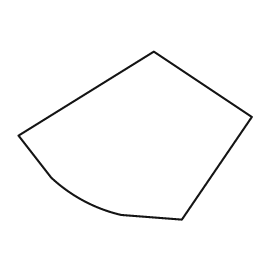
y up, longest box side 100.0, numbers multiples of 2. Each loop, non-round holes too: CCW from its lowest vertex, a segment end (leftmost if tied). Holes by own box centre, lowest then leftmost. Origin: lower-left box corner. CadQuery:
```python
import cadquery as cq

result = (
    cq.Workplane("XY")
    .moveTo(70.0, 0.0)
    .lineTo(100.0, 44.0)
    .lineTo(58.0, 72.0)
    .lineTo(0.0, 36.0)
    .lineTo(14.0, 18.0)
    .threePointArc((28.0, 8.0), (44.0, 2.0))
    .close()
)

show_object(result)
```